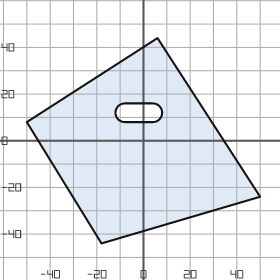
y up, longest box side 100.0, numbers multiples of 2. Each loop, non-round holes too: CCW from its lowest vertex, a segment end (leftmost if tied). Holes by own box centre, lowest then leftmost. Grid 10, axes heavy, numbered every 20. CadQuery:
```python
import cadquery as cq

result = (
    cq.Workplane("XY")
    .moveTo(-18.0, -44.0)
    .lineTo(50.0, -24.0)
    .lineTo(6.0, 44.0)
    .lineTo(-50.0, 8.0)
    .close()
    .moveTo(-8.0, 8.0)
    .lineTo(4.0, 8.0)
    .threePointArc((8.0, 12.0), (4.0, 16.0))
    .lineTo(-8.0, 16.0)
    .threePointArc((-12.0, 12.0), (-8.0, 8.0))
    .close()
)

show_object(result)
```